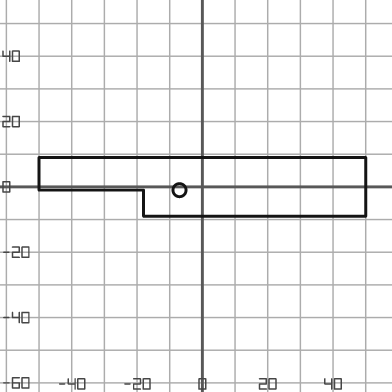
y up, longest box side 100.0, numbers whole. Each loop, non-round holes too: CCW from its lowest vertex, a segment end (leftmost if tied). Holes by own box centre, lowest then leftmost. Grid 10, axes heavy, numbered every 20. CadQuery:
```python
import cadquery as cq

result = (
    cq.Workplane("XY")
    .moveTo(-18.0, -9.0)
    .lineTo(50.0, -9.0)
    .lineTo(50.0, 9.0)
    .lineTo(-50.0, 9.0)
    .lineTo(-50.0, -1.0)
    .lineTo(-18.0, -1.0)
    .close()
    .moveTo(-7.0, -1.0)
    .circle(2.0)
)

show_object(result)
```